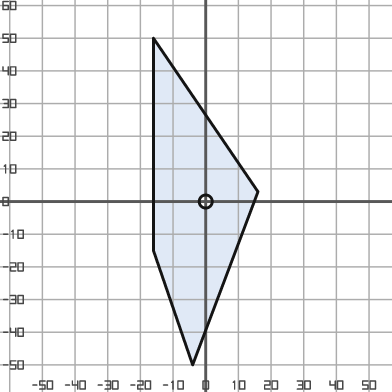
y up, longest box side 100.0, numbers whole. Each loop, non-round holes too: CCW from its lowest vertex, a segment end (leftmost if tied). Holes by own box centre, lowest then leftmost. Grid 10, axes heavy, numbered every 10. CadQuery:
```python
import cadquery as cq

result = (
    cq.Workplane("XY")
    .moveTo(-4.0, -50.0)
    .lineTo(16.0, 3.0)
    .lineTo(-16.0, 50.0)
    .lineTo(-16.0, -15.0)
    .close()
    .moveTo(0.0, 0.0)
    .circle(2.0)
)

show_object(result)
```